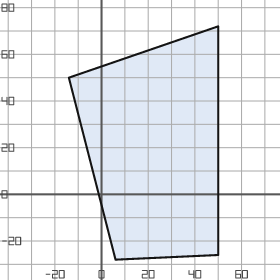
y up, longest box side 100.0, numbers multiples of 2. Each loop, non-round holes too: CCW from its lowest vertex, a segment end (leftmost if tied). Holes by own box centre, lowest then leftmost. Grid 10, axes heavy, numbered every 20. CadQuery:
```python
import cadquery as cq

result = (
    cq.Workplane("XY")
    .moveTo(6.0, -28.0)
    .lineTo(50.0, -26.0)
    .lineTo(50.0, 72.0)
    .lineTo(-14.0, 50.0)
    .close()
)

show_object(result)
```